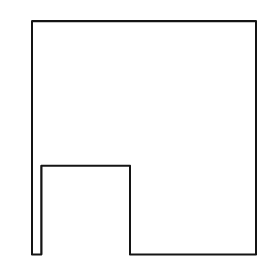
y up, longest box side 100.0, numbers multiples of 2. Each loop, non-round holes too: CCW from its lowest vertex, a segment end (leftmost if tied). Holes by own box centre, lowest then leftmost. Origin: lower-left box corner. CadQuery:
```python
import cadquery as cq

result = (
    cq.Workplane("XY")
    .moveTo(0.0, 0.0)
    .lineTo(4.0, 0.0)
    .lineTo(4.0, 38.0)
    .lineTo(42.0, 38.0)
    .lineTo(42.0, 0.0)
    .lineTo(96.0, 0.0)
    .lineTo(96.0, 100.0)
    .lineTo(0.0, 100.0)
    .close()
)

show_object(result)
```